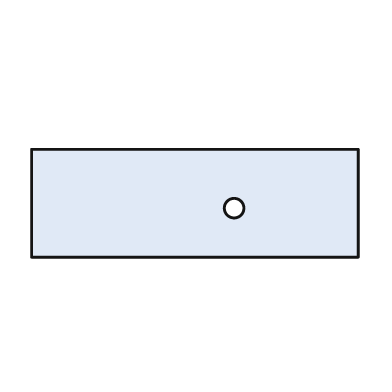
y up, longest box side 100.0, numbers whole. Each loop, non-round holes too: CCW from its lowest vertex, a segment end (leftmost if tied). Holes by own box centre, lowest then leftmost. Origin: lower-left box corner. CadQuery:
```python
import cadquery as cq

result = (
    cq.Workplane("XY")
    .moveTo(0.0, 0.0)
    .lineTo(100.0, 0.0)
    .lineTo(100.0, 33.0)
    .lineTo(0.0, 33.0)
    .close()
    .moveTo(62.0, 15.0)
    .circle(3.0)
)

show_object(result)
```